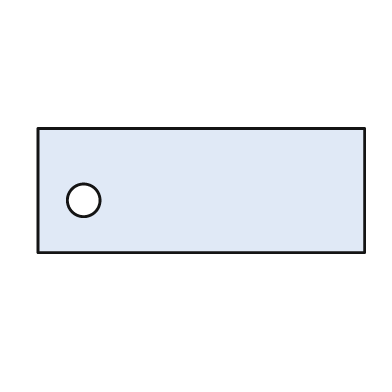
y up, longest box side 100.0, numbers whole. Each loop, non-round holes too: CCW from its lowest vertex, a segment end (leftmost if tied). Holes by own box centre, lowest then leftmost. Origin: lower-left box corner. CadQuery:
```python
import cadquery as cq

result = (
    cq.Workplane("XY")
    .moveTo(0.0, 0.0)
    .lineTo(100.0, 0.0)
    .lineTo(100.0, 38.0)
    .lineTo(0.0, 38.0)
    .close()
    .moveTo(14.0, 16.0)
    .circle(5.0)
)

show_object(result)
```